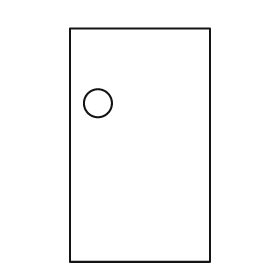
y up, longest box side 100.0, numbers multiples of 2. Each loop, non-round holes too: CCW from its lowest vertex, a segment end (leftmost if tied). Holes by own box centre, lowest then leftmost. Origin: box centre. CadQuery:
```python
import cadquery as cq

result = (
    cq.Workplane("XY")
    .moveTo(-30.0, -50.0)
    .lineTo(30.0, -50.0)
    .lineTo(30.0, 50.0)
    .lineTo(-30.0, 50.0)
    .close()
    .moveTo(-18.0, 18.0)
    .circle(6.0)
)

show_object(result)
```